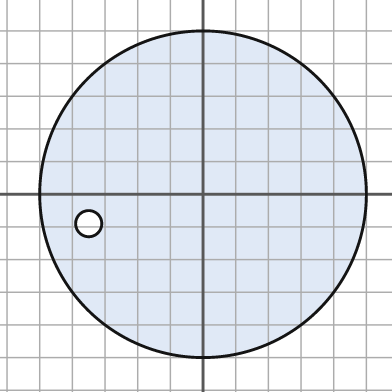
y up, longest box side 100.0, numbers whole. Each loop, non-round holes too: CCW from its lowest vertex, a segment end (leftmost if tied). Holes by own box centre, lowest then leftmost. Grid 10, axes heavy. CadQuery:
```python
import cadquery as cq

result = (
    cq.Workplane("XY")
    .moveTo(0.0, 0.0)
    .circle(50.0)
    .moveTo(-35.0, -9.0)
    .circle(4.0)
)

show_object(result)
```